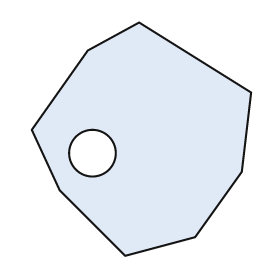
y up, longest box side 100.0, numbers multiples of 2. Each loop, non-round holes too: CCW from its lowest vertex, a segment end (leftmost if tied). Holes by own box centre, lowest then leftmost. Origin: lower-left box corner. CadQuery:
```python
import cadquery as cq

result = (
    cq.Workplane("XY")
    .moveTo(40.0, 0.0)
    .lineTo(70.0, 8.0)
    .lineTo(90.0, 36.0)
    .lineTo(94.0, 70.0)
    .lineTo(46.0, 100.0)
    .lineTo(24.0, 88.0)
    .lineTo(0.0, 54.0)
    .lineTo(12.0, 28.0)
    .close()
    .moveTo(26.0, 44.0)
    .circle(10.0)
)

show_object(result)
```